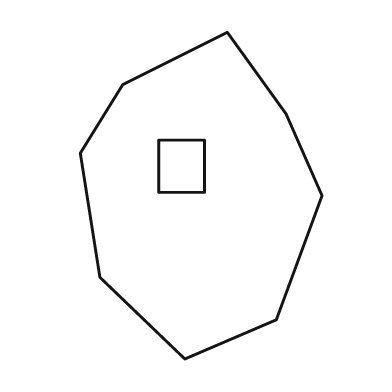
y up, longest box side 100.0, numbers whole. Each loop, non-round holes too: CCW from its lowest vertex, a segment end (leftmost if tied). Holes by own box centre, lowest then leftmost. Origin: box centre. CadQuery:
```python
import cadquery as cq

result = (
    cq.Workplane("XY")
    .moveTo(-5.0, -50.0)
    .lineTo(23.0, -38.0)
    .lineTo(37.0, 0.0)
    .lineTo(26.0, 25.0)
    .lineTo(8.0, 50.0)
    .lineTo(-24.0, 34.0)
    .lineTo(-37.0, 13.0)
    .lineTo(-31.0, -25.0)
    .close()
    .moveTo(-13.0, 1.0)
    .lineTo(1.0, 1.0)
    .lineTo(1.0, 17.0)
    .lineTo(-13.0, 17.0)
    .close()
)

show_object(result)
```